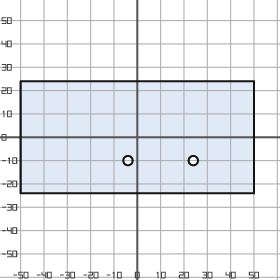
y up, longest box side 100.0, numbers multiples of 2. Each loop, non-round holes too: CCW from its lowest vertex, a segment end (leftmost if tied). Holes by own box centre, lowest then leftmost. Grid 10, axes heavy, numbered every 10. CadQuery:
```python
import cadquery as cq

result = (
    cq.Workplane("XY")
    .moveTo(-50.0, -24.0)
    .lineTo(50.0, -24.0)
    .lineTo(50.0, 24.0)
    .lineTo(-50.0, 24.0)
    .close()
    .moveTo(-4.0, -10.0)
    .circle(2.0)
    .moveTo(24.0, -10.0)
    .circle(2.0)
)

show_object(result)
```